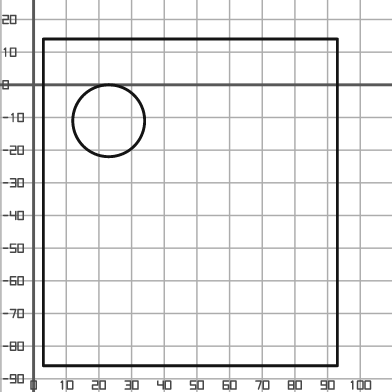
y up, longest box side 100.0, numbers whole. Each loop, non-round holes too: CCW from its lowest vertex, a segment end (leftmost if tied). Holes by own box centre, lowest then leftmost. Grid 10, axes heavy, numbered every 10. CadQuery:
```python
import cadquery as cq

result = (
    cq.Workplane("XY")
    .moveTo(3.0, -86.0)
    .lineTo(93.0, -86.0)
    .lineTo(93.0, 14.0)
    .lineTo(3.0, 14.0)
    .close()
    .moveTo(23.0, -11.0)
    .circle(11.0)
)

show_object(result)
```